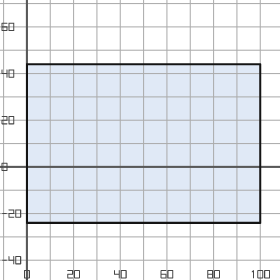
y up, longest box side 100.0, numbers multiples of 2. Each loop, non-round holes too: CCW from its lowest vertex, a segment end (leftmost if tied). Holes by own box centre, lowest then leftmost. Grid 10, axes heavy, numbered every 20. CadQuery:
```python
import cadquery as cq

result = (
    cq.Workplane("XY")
    .moveTo(0.0, -24.0)
    .lineTo(100.0, -24.0)
    .lineTo(100.0, 44.0)
    .lineTo(0.0, 44.0)
    .close()
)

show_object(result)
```